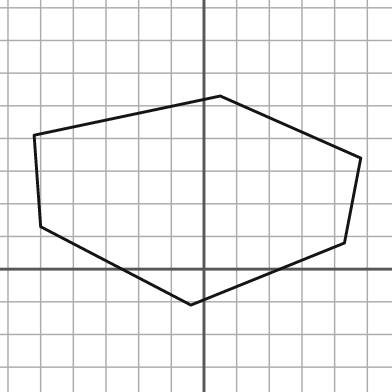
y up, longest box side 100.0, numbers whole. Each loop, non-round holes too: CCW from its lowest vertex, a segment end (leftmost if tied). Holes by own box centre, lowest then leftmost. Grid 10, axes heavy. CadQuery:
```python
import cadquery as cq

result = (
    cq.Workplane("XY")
    .moveTo(-4.0, -11.0)
    .lineTo(43.0, 8.0)
    .lineTo(48.0, 34.0)
    .lineTo(5.0, 53.0)
    .lineTo(-52.0, 41.0)
    .lineTo(-50.0, 13.0)
    .close()
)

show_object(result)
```